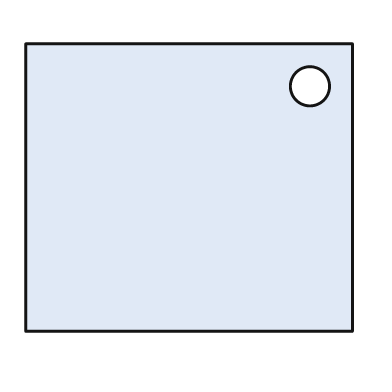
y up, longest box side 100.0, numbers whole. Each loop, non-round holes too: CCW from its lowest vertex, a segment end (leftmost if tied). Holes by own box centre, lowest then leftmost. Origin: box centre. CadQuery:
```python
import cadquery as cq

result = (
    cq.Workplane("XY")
    .moveTo(-50.0, -44.0)
    .lineTo(50.0, -44.0)
    .lineTo(50.0, 44.0)
    .lineTo(-50.0, 44.0)
    .close()
    .moveTo(37.0, 31.0)
    .circle(6.0)
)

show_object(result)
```